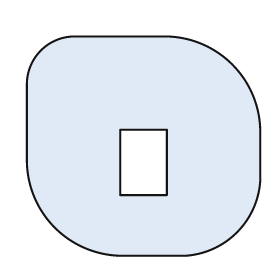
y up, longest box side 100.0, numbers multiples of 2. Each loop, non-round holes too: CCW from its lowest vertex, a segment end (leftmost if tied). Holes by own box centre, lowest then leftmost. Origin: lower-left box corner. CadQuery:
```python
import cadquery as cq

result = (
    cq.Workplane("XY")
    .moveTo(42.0, 0.0)
    .lineTo(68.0, 0.0)
    .threePointArc((90.0, 10.0), (100.0, 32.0))
    .lineTo(100.0, 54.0)
    .threePointArc((88.0, 82.0), (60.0, 94.0))
    .lineTo(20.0, 94.0)
    .threePointArc((6.0, 88.0), (0.0, 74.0))
    .lineTo(0.0, 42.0)
    .threePointArc((12.0, 12.0), (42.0, 0.0))
    .close()
    .moveTo(40.0, 26.0)
    .lineTo(60.0, 26.0)
    .lineTo(60.0, 54.0)
    .lineTo(40.0, 54.0)
    .close()
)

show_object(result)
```